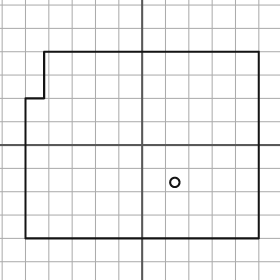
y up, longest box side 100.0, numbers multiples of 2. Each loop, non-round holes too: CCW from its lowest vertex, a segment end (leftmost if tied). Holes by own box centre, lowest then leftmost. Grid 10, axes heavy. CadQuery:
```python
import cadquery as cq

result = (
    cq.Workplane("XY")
    .moveTo(-50.0, -40.0)
    .lineTo(50.0, -40.0)
    .lineTo(50.0, 40.0)
    .lineTo(-42.0, 40.0)
    .lineTo(-42.0, 20.0)
    .lineTo(-50.0, 20.0)
    .close()
    .moveTo(14.0, -16.0)
    .circle(2.0)
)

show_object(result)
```